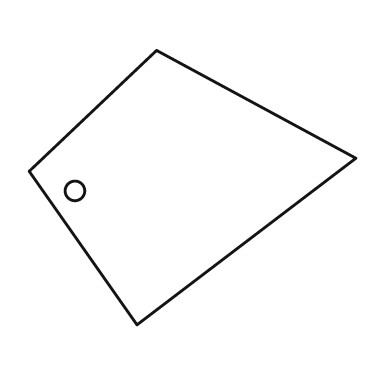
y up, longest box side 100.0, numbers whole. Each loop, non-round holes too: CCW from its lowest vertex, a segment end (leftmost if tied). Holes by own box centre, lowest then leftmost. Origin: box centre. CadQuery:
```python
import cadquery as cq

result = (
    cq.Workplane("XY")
    .moveTo(-17.0, -42.0)
    .lineTo(50.0, 9.0)
    .lineTo(-11.0, 42.0)
    .lineTo(-50.0, 5.0)
    .close()
    .moveTo(-36.0, -1.0)
    .circle(3.0)
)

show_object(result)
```